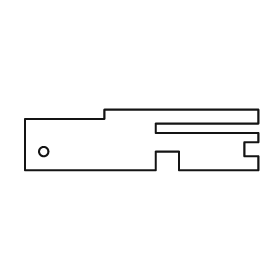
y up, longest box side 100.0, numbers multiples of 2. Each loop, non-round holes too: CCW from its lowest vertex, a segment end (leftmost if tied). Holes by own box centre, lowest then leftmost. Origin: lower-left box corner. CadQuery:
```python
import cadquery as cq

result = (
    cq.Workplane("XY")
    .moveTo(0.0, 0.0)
    .lineTo(56.0, 0.0)
    .lineTo(56.0, 8.0)
    .lineTo(66.0, 8.0)
    .lineTo(66.0, 0.0)
    .lineTo(100.0, 0.0)
    .lineTo(100.0, 6.0)
    .lineTo(94.0, 6.0)
    .lineTo(94.0, 12.0)
    .lineTo(100.0, 12.0)
    .lineTo(100.0, 16.0)
    .lineTo(56.0, 16.0)
    .lineTo(56.0, 20.0)
    .lineTo(100.0, 20.0)
    .lineTo(100.0, 26.0)
    .lineTo(34.0, 26.0)
    .lineTo(34.0, 22.0)
    .lineTo(0.0, 22.0)
    .close()
    .moveTo(8.0, 8.0)
    .circle(2.0)
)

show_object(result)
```